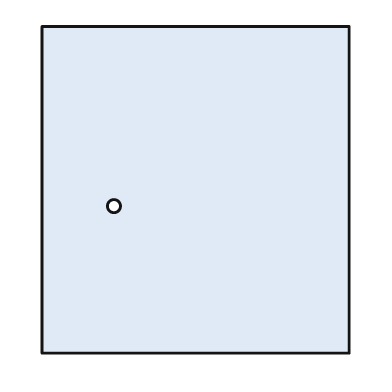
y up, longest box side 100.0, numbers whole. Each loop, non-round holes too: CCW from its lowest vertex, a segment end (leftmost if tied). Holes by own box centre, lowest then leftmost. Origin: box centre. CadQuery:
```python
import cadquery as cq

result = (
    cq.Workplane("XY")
    .moveTo(-47.0, -50.0)
    .lineTo(47.0, -50.0)
    .lineTo(47.0, 50.0)
    .lineTo(-47.0, 50.0)
    .close()
    .moveTo(-25.0, -5.0)
    .circle(2.0)
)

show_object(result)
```